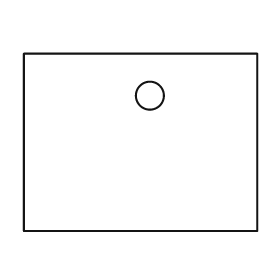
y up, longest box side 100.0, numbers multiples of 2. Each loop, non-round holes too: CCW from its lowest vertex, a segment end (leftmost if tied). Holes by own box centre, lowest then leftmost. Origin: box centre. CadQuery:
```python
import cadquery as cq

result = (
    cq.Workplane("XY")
    .moveTo(-50.0, -38.0)
    .lineTo(50.0, -38.0)
    .lineTo(50.0, 38.0)
    .lineTo(-50.0, 38.0)
    .close()
    .moveTo(4.0, 20.0)
    .circle(6.0)
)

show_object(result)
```